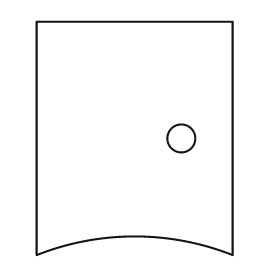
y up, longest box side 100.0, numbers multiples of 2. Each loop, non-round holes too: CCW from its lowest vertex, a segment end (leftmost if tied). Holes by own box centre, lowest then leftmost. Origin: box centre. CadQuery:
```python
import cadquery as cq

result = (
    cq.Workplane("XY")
    .moveTo(-42.0, -50.0)
    .threePointArc((0.0, -42.0), (42.0, -50.0))
    .lineTo(42.0, 50.0)
    .lineTo(-42.0, 50.0)
    .close()
    .moveTo(20.0, 0.0)
    .circle(6.0)
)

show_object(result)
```